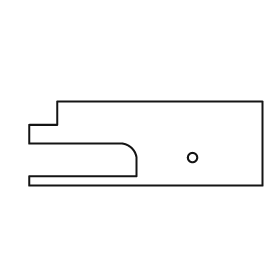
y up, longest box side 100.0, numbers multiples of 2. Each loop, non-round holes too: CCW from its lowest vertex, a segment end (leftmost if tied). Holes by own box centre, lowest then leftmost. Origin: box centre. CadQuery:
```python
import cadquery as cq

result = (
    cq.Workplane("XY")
    .moveTo(-50.0, -18.0)
    .lineTo(50.0, -18.0)
    .lineTo(50.0, 18.0)
    .lineTo(-38.0, 18.0)
    .lineTo(-38.0, 8.0)
    .lineTo(-50.0, 8.0)
    .lineTo(-50.0, 0.0)
    .lineTo(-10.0, 0.0)
    .threePointArc((-6.0, -2.0), (-4.0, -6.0))
    .lineTo(-4.0, -14.0)
    .lineTo(-50.0, -14.0)
    .close()
    .moveTo(20.0, -6.0)
    .circle(2.0)
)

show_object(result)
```